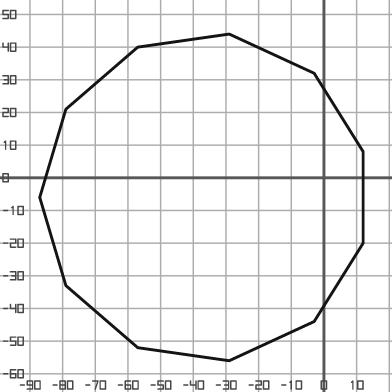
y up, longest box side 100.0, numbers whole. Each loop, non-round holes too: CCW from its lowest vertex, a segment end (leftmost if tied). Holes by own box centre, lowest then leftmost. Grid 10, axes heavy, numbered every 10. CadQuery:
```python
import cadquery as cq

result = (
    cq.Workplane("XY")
    .moveTo(-29.0, -56.0)
    .lineTo(-3.0, -44.0)
    .lineTo(12.0, -20.0)
    .lineTo(12.0, 8.0)
    .lineTo(-3.0, 32.0)
    .lineTo(-29.0, 44.0)
    .lineTo(-57.0, 40.0)
    .lineTo(-79.0, 21.0)
    .lineTo(-87.0, -6.0)
    .lineTo(-79.0, -33.0)
    .lineTo(-57.0, -52.0)
    .close()
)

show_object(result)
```